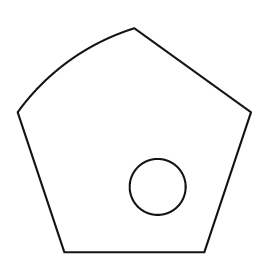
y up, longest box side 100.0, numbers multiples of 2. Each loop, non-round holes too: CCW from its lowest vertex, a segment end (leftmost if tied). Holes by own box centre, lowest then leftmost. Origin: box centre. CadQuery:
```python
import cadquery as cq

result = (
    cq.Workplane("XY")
    .moveTo(-30.0, -48.0)
    .lineTo(30.0, -48.0)
    .lineTo(50.0, 12.0)
    .lineTo(0.0, 48.0)
    .threePointArc((-28.0, 34.0), (-50.0, 12.0))
    .close()
    .moveTo(10.0, -20.0)
    .circle(12.0)
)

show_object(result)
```